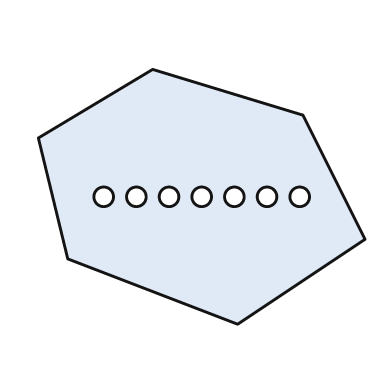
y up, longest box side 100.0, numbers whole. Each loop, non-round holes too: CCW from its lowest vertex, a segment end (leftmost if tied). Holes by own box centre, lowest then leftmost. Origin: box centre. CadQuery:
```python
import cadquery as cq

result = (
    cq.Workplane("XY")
    .moveTo(11.0, -39.0)
    .lineTo(50.0, -13.0)
    .lineTo(31.0, 25.0)
    .lineTo(-15.0, 39.0)
    .lineTo(-50.0, 18.0)
    .lineTo(-41.0, -19.0)
    .close()
    .moveTo(-30.0, 0.0)
    .circle(3.0)
    .moveTo(-20.0, 0.0)
    .circle(3.0)
    .moveTo(-10.0, 0.0)
    .circle(3.0)
    .moveTo(0.0, 0.0)
    .circle(3.0)
    .moveTo(10.0, 0.0)
    .circle(3.0)
    .moveTo(20.0, 0.0)
    .circle(3.0)
    .moveTo(30.0, 0.0)
    .circle(3.0)
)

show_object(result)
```